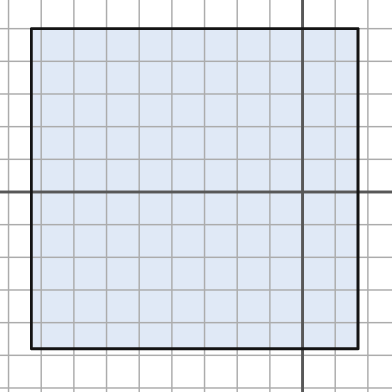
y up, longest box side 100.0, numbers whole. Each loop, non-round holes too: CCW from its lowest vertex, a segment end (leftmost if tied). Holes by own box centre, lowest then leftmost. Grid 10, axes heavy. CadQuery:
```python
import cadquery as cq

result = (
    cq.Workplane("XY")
    .moveTo(-83.0, -48.0)
    .lineTo(17.0, -48.0)
    .lineTo(17.0, 50.0)
    .lineTo(-83.0, 50.0)
    .close()
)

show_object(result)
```